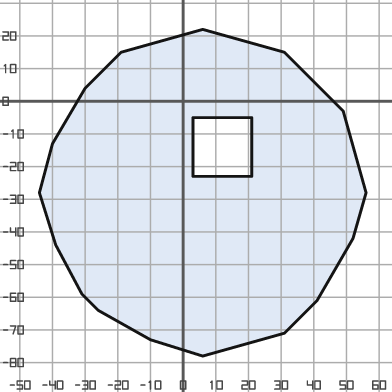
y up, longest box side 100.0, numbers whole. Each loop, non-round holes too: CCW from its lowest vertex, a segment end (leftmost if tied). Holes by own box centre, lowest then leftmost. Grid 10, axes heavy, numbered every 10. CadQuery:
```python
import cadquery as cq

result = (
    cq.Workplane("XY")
    .moveTo(6.0, -78.0)
    .lineTo(31.0, -71.0)
    .lineTo(41.0, -61.0)
    .lineTo(52.0, -42.0)
    .lineTo(56.0, -28.0)
    .lineTo(49.0, -3.0)
    .lineTo(31.0, 15.0)
    .lineTo(6.0, 22.0)
    .lineTo(-19.0, 15.0)
    .lineTo(-30.0, 4.0)
    .lineTo(-40.0, -13.0)
    .lineTo(-44.0, -28.0)
    .lineTo(-39.0, -44.0)
    .lineTo(-31.0, -59.0)
    .lineTo(-26.0, -64.0)
    .lineTo(-10.0, -73.0)
    .close()
    .moveTo(3.0, -23.0)
    .lineTo(21.0, -23.0)
    .lineTo(21.0, -5.0)
    .lineTo(3.0, -5.0)
    .close()
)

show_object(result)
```